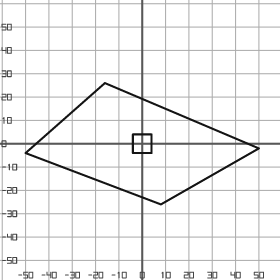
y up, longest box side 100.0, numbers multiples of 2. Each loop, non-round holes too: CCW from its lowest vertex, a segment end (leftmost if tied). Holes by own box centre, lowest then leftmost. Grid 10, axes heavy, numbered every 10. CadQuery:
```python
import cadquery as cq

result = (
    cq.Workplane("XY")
    .moveTo(8.0, -26.0)
    .lineTo(50.0, -2.0)
    .lineTo(-16.0, 26.0)
    .lineTo(-50.0, -4.0)
    .close()
    .moveTo(-4.0, -4.0)
    .lineTo(4.0, -4.0)
    .lineTo(4.0, 4.0)
    .lineTo(-4.0, 4.0)
    .close()
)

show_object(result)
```